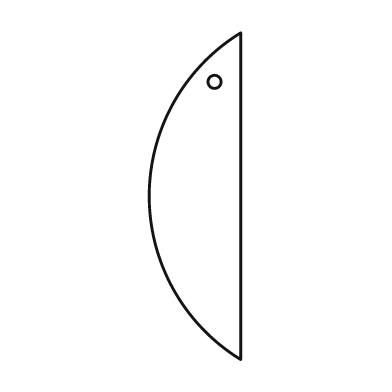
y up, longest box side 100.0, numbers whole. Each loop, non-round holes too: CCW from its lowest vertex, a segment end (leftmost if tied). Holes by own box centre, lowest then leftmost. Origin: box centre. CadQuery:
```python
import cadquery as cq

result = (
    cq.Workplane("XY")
    .moveTo(14.0, -50.0)
    .lineTo(14.0, 50.0)
    .threePointArc((-14.0, 0.0), (14.0, -50.0))
    .close()
    .moveTo(6.0, 35.0)
    .circle(2.0)
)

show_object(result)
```